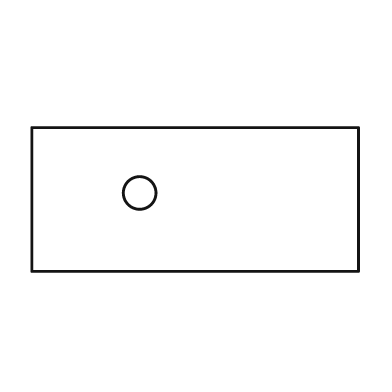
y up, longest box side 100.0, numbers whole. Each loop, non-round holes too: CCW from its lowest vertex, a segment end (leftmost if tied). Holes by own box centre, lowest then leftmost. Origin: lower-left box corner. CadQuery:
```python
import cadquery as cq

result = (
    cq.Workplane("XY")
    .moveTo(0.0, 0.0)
    .lineTo(100.0, 0.0)
    .lineTo(100.0, 44.0)
    .lineTo(0.0, 44.0)
    .close()
    .moveTo(33.0, 24.0)
    .circle(5.0)
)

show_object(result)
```